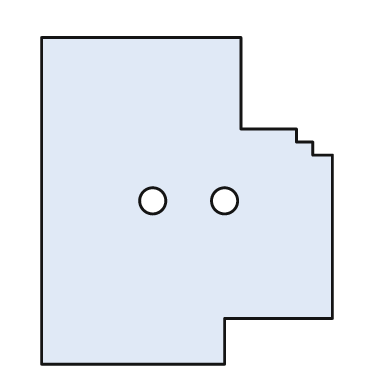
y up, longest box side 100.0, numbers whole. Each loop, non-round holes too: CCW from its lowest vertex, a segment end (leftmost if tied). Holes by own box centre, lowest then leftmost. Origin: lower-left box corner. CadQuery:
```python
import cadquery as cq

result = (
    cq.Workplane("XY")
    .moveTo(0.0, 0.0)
    .lineTo(56.0, 0.0)
    .lineTo(56.0, 14.0)
    .lineTo(89.0, 14.0)
    .lineTo(89.0, 64.0)
    .lineTo(83.0, 64.0)
    .lineTo(83.0, 68.0)
    .lineTo(78.0, 68.0)
    .lineTo(78.0, 72.0)
    .lineTo(61.0, 72.0)
    .lineTo(61.0, 100.0)
    .lineTo(0.0, 100.0)
    .close()
    .moveTo(34.0, 50.0)
    .circle(4.0)
    .moveTo(56.0, 50.0)
    .circle(4.0)
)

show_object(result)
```